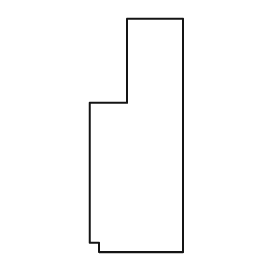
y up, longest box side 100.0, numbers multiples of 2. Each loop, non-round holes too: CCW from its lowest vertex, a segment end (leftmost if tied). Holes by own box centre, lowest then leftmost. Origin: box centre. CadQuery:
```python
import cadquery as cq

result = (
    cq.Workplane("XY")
    .moveTo(-16.0, -50.0)
    .lineTo(20.0, -50.0)
    .lineTo(20.0, 50.0)
    .lineTo(-4.0, 50.0)
    .lineTo(-4.0, 14.0)
    .lineTo(-20.0, 14.0)
    .lineTo(-20.0, -46.0)
    .lineTo(-16.0, -46.0)
    .close()
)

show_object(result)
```